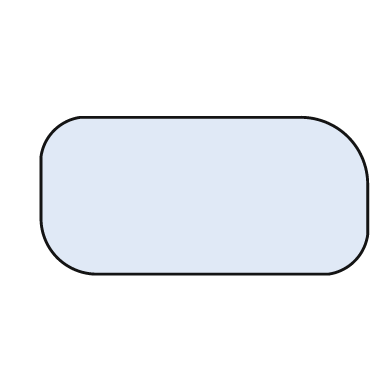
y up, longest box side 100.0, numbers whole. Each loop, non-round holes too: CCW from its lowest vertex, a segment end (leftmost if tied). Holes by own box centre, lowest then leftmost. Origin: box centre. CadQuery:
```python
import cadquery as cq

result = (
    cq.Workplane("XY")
    .moveTo(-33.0, -24.0)
    .lineTo(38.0, -24.0)
    .threePointArc((46.0, -20.0), (50.0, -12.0))
    .lineTo(50.0, 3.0)
    .threePointArc((44.0, 18.0), (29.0, 24.0))
    .lineTo(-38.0, 24.0)
    .threePointArc((-46.0, 20.0), (-50.0, 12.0))
    .lineTo(-50.0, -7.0)
    .threePointArc((-45.0, -19.0), (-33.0, -24.0))
    .close()
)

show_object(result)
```